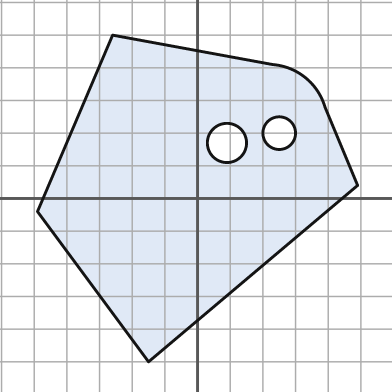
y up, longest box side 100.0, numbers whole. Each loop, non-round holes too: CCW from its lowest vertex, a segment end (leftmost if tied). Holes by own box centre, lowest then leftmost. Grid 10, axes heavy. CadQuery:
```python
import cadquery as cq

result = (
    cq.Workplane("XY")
    .moveTo(-15.0, -50.0)
    .lineTo(49.0, 4.0)
    .lineTo(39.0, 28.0)
    .threePointArc((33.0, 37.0), (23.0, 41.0))
    .lineTo(-26.0, 50.0)
    .lineTo(-49.0, -4.0)
    .close()
    .moveTo(9.0, 17.0)
    .circle(6.0)
    .moveTo(25.0, 20.0)
    .circle(5.0)
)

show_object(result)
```